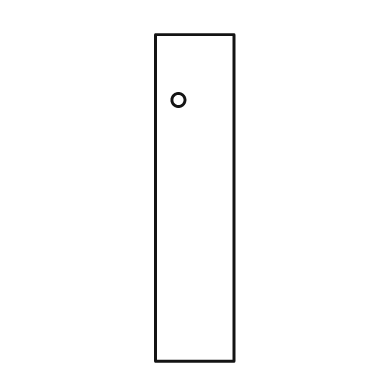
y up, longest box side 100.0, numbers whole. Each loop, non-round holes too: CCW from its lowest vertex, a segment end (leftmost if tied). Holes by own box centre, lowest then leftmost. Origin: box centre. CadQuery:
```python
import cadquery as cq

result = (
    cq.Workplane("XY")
    .moveTo(-12.0, -50.0)
    .lineTo(12.0, -50.0)
    .lineTo(12.0, 50.0)
    .lineTo(-12.0, 50.0)
    .close()
    .moveTo(-5.0, 30.0)
    .circle(2.0)
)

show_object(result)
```